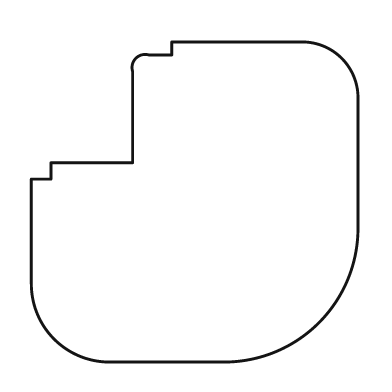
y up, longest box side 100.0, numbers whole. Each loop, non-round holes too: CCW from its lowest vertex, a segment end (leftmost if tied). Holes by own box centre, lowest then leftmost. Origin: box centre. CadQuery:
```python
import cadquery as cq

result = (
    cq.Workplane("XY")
    .moveTo(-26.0, -49.0)
    .lineTo(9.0, -49.0)
    .threePointArc((38.0, -37.0), (50.0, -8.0))
    .lineTo(50.0, 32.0)
    .threePointArc((45.0, 44.0), (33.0, 49.0))
    .lineTo(-7.0, 49.0)
    .lineTo(-7.0, 45.0)
    .lineTo(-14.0, 45.0)
    .threePointArc((-18.0, 44.0), (-19.0, 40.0))
    .lineTo(-19.0, 12.0)
    .lineTo(-44.0, 12.0)
    .lineTo(-44.0, 7.0)
    .lineTo(-50.0, 7.0)
    .lineTo(-50.0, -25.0)
    .threePointArc((-43.0, -42.0), (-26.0, -49.0))
    .close()
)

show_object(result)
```